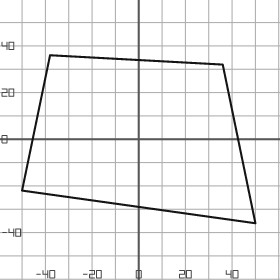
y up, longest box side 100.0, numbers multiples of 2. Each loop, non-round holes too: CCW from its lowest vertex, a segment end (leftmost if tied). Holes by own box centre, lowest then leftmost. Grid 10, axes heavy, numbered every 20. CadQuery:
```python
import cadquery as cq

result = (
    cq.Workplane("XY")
    .moveTo(50.0, -36.0)
    .lineTo(36.0, 32.0)
    .lineTo(-38.0, 36.0)
    .lineTo(-50.0, -22.0)
    .close()
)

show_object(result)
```